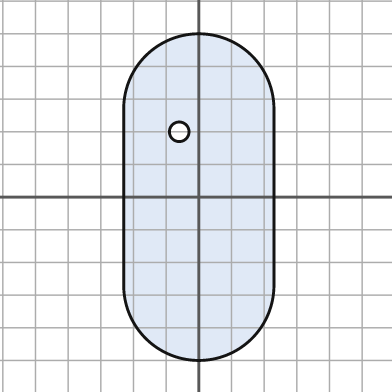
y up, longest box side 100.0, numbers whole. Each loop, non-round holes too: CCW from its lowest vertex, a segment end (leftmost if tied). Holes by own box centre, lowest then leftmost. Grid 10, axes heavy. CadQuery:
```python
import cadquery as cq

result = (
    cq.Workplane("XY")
    .moveTo(-23.0, -27.0)
    .threePointArc((0.0, -50.0), (23.0, -27.0))
    .lineTo(23.0, 27.0)
    .threePointArc((0.0, 50.0), (-23.0, 27.0))
    .close()
    .moveTo(-6.0, 20.0)
    .circle(3.0)
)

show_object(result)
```